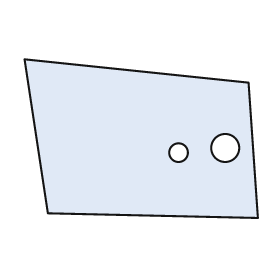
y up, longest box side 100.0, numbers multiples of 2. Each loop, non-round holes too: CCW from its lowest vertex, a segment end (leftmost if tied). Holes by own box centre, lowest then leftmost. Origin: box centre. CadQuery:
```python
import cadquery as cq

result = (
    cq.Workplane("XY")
    .moveTo(50.0, -34.0)
    .lineTo(46.0, 24.0)
    .lineTo(-50.0, 34.0)
    .lineTo(-40.0, -32.0)
    .close()
    .moveTo(16.0, -6.0)
    .circle(4.0)
    .moveTo(36.0, -4.0)
    .circle(6.0)
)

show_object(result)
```